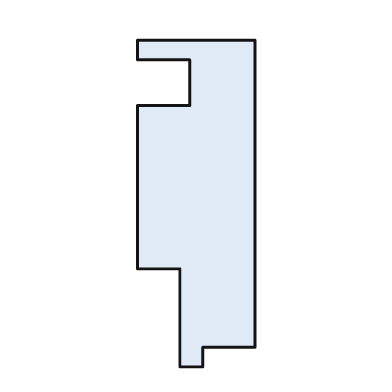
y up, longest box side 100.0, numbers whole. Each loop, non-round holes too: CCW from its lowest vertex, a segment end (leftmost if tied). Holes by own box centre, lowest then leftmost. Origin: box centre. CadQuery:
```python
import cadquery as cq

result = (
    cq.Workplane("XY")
    .moveTo(-5.0, -50.0)
    .lineTo(2.0, -50.0)
    .lineTo(2.0, -44.0)
    .lineTo(18.0, -44.0)
    .lineTo(18.0, 50.0)
    .lineTo(-18.0, 50.0)
    .lineTo(-18.0, 44.0)
    .lineTo(-2.0, 44.0)
    .lineTo(-2.0, 30.0)
    .lineTo(-18.0, 30.0)
    .lineTo(-18.0, -20.0)
    .lineTo(-5.0, -20.0)
    .close()
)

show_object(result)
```